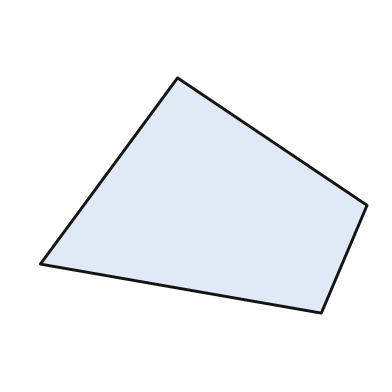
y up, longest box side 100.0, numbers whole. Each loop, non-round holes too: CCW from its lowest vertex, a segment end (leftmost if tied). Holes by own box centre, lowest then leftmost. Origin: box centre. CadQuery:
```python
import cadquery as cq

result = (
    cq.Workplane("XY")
    .moveTo(36.0, -36.0)
    .lineTo(50.0, -3.0)
    .lineTo(-8.0, 36.0)
    .lineTo(-50.0, -21.0)
    .close()
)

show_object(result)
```